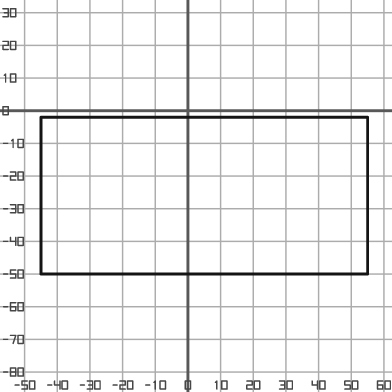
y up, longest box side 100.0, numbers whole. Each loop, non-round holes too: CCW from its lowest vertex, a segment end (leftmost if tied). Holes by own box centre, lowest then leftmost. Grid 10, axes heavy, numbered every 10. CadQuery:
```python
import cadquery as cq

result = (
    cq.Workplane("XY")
    .moveTo(-45.0, -50.0)
    .lineTo(55.0, -50.0)
    .lineTo(55.0, -2.0)
    .lineTo(-45.0, -2.0)
    .close()
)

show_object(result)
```